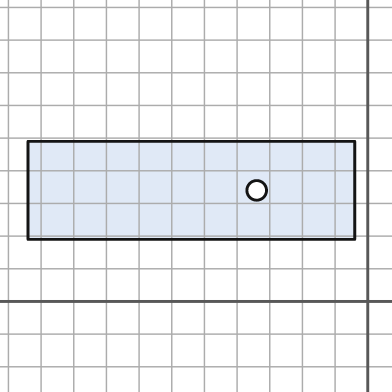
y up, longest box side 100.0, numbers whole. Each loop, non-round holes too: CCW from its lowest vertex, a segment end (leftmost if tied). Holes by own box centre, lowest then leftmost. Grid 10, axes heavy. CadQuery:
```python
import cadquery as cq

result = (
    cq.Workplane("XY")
    .moveTo(-104.0, 19.0)
    .lineTo(-4.0, 19.0)
    .lineTo(-4.0, 49.0)
    .lineTo(-104.0, 49.0)
    .close()
    .moveTo(-34.0, 34.0)
    .circle(3.0)
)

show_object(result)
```